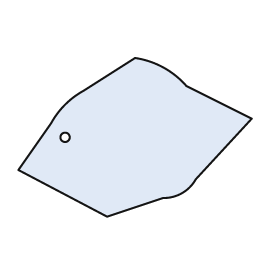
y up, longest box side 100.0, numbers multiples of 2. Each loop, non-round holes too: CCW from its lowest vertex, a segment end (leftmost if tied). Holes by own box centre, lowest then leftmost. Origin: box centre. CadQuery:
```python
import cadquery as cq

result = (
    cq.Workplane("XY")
    .moveTo(-12.0, -34.0)
    .lineTo(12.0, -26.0)
    .threePointArc((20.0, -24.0), (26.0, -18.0))
    .lineTo(50.0, 8.0)
    .lineTo(22.0, 22.0)
    .threePointArc((12.0, 30.0), (0.0, 34.0))
    .lineTo(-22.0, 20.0)
    .threePointArc((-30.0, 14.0), (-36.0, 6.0))
    .lineTo(-50.0, -14.0)
    .close()
    .moveTo(-30.0, 0.0)
    .circle(2.0)
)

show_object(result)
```